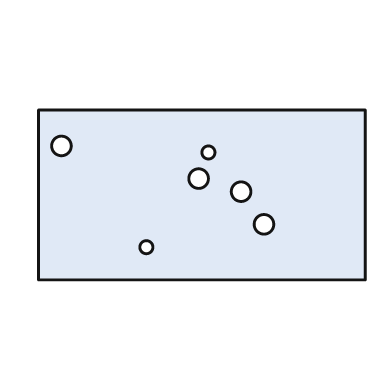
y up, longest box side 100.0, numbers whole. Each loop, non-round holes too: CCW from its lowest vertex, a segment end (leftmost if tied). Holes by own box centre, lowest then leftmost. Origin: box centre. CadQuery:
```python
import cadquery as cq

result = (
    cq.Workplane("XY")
    .moveTo(-50.0, -26.0)
    .lineTo(50.0, -26.0)
    .lineTo(50.0, 26.0)
    .lineTo(-50.0, 26.0)
    .close()
    .moveTo(-17.0, -16.0)
    .circle(2.0)
    .moveTo(19.0, -9.0)
    .circle(3.0)
    .moveTo(12.0, 1.0)
    .circle(3.0)
    .moveTo(-1.0, 5.0)
    .circle(3.0)
    .moveTo(2.0, 13.0)
    .circle(2.0)
    .moveTo(-43.0, 15.0)
    .circle(3.0)
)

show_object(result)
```